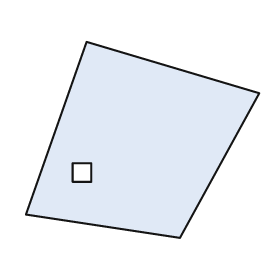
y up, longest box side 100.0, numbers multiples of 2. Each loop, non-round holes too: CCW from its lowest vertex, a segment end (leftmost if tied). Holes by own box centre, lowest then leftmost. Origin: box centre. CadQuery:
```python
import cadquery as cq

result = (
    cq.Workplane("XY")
    .moveTo(16.0, -42.0)
    .lineTo(50.0, 20.0)
    .lineTo(-24.0, 42.0)
    .lineTo(-50.0, -32.0)
    .close()
    .moveTo(-30.0, -18.0)
    .lineTo(-22.0, -18.0)
    .lineTo(-22.0, -10.0)
    .lineTo(-30.0, -10.0)
    .close()
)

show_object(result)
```